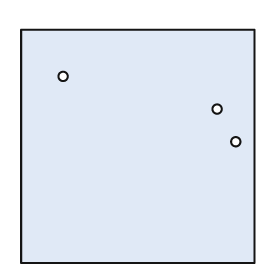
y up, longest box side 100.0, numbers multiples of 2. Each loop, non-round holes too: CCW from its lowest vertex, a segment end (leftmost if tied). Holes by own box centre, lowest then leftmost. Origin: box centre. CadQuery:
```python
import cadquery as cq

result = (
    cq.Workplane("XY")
    .moveTo(-50.0, -50.0)
    .lineTo(50.0, -50.0)
    .lineTo(50.0, 50.0)
    .lineTo(-50.0, 50.0)
    .close()
    .moveTo(42.0, 2.0)
    .circle(2.0)
    .moveTo(34.0, 16.0)
    .circle(2.0)
    .moveTo(-32.0, 30.0)
    .circle(2.0)
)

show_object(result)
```